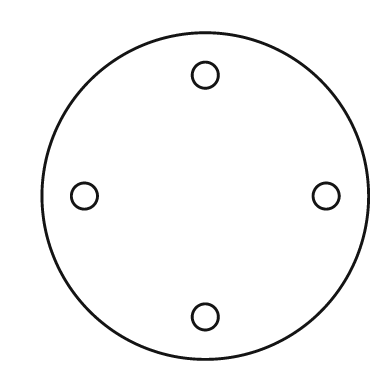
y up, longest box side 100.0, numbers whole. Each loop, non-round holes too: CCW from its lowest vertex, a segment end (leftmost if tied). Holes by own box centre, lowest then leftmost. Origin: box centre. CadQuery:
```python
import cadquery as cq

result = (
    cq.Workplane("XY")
    .moveTo(0.0, 0.0)
    .circle(50.0)
    .moveTo(0.0, -37.0)
    .circle(4.0)
    .moveTo(-37.0, 0.0)
    .circle(4.0)
    .moveTo(37.0, 0.0)
    .circle(4.0)
    .moveTo(0.0, 37.0)
    .circle(4.0)
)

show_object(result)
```